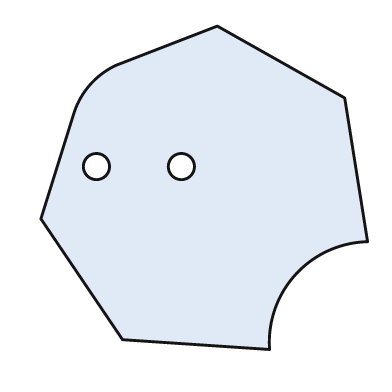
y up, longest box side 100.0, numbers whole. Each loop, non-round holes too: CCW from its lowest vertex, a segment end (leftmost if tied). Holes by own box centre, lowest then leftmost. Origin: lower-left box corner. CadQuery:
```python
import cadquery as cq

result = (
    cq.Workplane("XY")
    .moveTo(70.0, 0.0)
    .threePointArc((78.0, 23.0), (100.0, 33.0))
    .lineTo(93.0, 77.0)
    .lineTo(54.0, 99.0)
    .lineTo(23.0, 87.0)
    .threePointArc((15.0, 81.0), (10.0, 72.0))
    .lineTo(0.0, 40.0)
    .lineTo(25.0, 3.0)
    .close()
    .moveTo(17.0, 56.0)
    .circle(4.0)
    .moveTo(43.0, 56.0)
    .circle(4.0)
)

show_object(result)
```